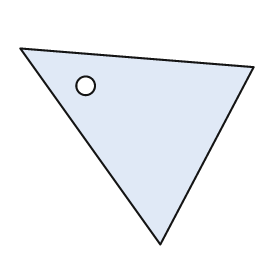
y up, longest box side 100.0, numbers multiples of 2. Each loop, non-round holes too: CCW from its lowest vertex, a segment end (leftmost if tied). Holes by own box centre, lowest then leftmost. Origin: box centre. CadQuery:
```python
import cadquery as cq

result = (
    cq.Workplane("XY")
    .moveTo(10.0, -42.0)
    .lineTo(50.0, 34.0)
    .lineTo(-50.0, 42.0)
    .close()
    .moveTo(-22.0, 26.0)
    .circle(4.0)
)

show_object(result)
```